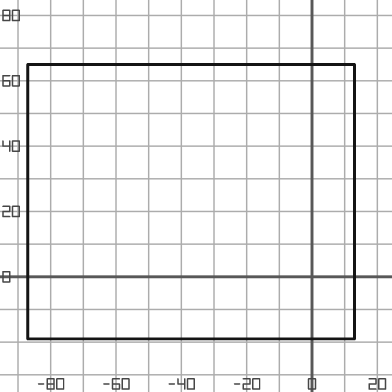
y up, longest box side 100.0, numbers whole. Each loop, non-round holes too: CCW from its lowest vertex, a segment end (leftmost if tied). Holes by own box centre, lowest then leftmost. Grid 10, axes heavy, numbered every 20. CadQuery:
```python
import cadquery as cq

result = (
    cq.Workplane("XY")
    .moveTo(-87.0, -19.0)
    .lineTo(13.0, -19.0)
    .lineTo(13.0, 65.0)
    .lineTo(-87.0, 65.0)
    .close()
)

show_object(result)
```